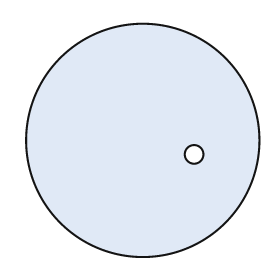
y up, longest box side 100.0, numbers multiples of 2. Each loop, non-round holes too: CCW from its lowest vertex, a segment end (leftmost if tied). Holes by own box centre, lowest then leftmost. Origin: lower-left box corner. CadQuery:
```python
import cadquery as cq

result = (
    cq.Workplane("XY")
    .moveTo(50.0, 50.0)
    .circle(50.0)
    .moveTo(72.0, 44.0)
    .circle(4.0)
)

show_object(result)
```